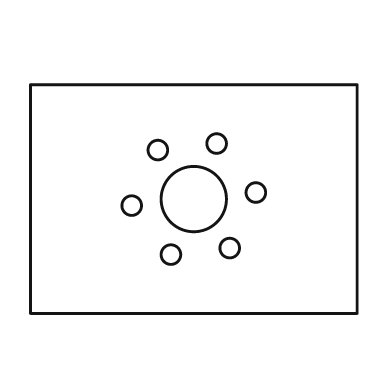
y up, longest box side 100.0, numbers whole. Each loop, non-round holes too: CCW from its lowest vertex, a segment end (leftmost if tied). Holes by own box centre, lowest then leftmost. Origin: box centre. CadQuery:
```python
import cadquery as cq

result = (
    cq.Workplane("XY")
    .moveTo(-50.0, -35.0)
    .lineTo(50.0, -35.0)
    .lineTo(50.0, 35.0)
    .lineTo(-50.0, 35.0)
    .close()
    .moveTo(-7.0, -17.0)
    .circle(3.0)
    .moveTo(11.0, -15.0)
    .circle(3.0)
    .moveTo(-19.0, -2.0)
    .circle(3.0)
    .moveTo(0.0, 0.0)
    .circle(10.0)
    .moveTo(19.0, 2.0)
    .circle(3.0)
    .moveTo(-11.0, 15.0)
    .circle(3.0)
    .moveTo(7.0, 17.0)
    .circle(3.0)
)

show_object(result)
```